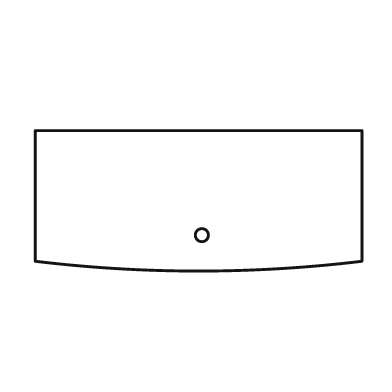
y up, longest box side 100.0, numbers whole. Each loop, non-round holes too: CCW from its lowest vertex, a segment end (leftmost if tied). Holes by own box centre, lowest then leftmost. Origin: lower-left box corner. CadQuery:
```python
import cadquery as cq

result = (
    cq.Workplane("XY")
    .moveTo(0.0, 3.0)
    .threePointArc((50.0, 0.0), (100.0, 3.0))
    .lineTo(100.0, 43.0)
    .lineTo(0.0, 43.0)
    .close()
    .moveTo(51.0, 11.0)
    .circle(2.0)
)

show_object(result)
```